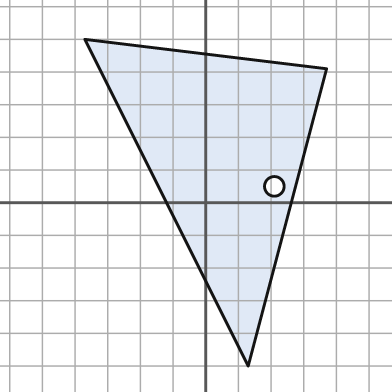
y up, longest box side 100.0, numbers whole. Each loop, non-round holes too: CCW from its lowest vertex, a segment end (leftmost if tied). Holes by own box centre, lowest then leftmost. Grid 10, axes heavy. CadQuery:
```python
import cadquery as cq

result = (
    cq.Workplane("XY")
    .moveTo(13.0, -50.0)
    .lineTo(37.0, 41.0)
    .lineTo(-37.0, 50.0)
    .close()
    .moveTo(21.0, 5.0)
    .circle(3.0)
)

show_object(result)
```